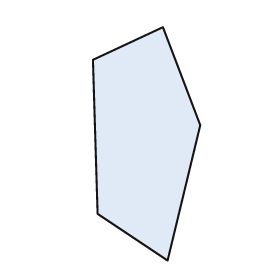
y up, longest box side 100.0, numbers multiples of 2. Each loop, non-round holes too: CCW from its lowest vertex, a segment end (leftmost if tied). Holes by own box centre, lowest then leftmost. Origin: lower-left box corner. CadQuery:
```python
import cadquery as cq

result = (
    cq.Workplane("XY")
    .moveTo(32.0, 0.0)
    .lineTo(46.0, 58.0)
    .lineTo(30.0, 100.0)
    .lineTo(0.0, 86.0)
    .lineTo(2.0, 20.0)
    .close()
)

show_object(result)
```